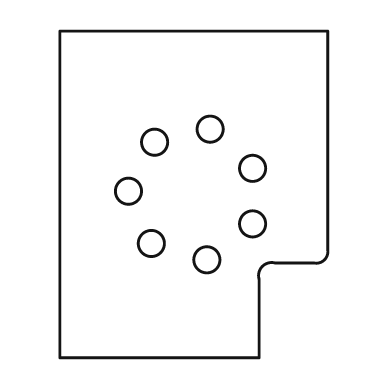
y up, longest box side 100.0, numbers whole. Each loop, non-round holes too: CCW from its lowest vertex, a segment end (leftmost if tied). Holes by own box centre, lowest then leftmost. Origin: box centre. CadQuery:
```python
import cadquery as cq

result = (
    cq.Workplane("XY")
    .moveTo(-41.0, -50.0)
    .lineTo(20.0, -50.0)
    .lineTo(20.0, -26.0)
    .threePointArc((21.0, -22.0), (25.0, -21.0))
    .lineTo(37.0, -21.0)
    .threePointArc((40.0, -20.0), (41.0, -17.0))
    .lineTo(41.0, 50.0)
    .lineTo(-41.0, 50.0)
    .close()
    .moveTo(4.0, -20.0)
    .circle(4.0)
    .moveTo(-13.0, -15.0)
    .circle(4.0)
    .moveTo(18.0, -9.0)
    .circle(4.0)
    .moveTo(-20.0, 1.0)
    .circle(4.0)
    .moveTo(18.0, 8.0)
    .circle(4.0)
    .moveTo(-12.0, 16.0)
    .circle(4.0)
    .moveTo(5.0, 20.0)
    .circle(4.0)
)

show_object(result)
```